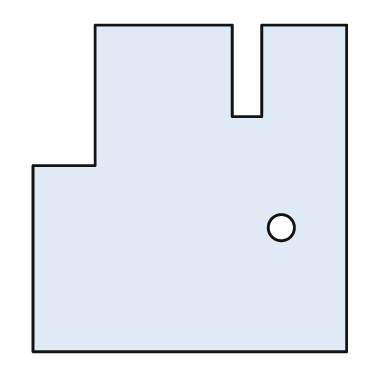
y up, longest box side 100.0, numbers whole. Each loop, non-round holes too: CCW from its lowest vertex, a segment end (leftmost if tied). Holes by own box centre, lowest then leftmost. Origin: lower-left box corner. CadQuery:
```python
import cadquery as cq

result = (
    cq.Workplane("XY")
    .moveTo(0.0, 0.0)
    .lineTo(96.0, 0.0)
    .lineTo(96.0, 100.0)
    .lineTo(70.0, 100.0)
    .lineTo(70.0, 72.0)
    .lineTo(61.0, 72.0)
    .lineTo(61.0, 100.0)
    .lineTo(19.0, 100.0)
    .lineTo(19.0, 57.0)
    .lineTo(0.0, 57.0)
    .close()
    .moveTo(76.0, 38.0)
    .circle(4.0)
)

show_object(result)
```